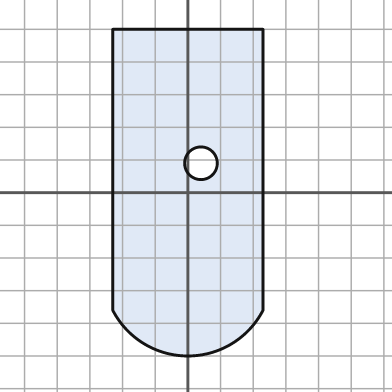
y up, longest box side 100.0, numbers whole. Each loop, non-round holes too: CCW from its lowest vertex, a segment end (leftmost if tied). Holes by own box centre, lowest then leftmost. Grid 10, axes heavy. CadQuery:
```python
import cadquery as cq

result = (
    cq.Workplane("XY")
    .moveTo(-23.0, -36.0)
    .threePointArc((0.0, -50.0), (23.0, -36.0))
    .lineTo(23.0, 50.0)
    .lineTo(-23.0, 50.0)
    .close()
    .moveTo(4.0, 9.0)
    .circle(5.0)
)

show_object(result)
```